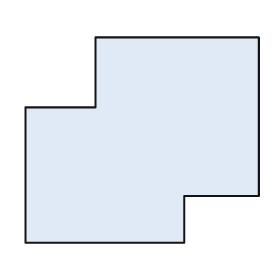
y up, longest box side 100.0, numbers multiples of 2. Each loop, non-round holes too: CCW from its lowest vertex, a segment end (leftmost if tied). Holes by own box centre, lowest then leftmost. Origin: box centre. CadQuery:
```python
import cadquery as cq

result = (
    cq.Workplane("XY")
    .moveTo(-50.0, -44.0)
    .lineTo(18.0, -44.0)
    .lineTo(18.0, -24.0)
    .lineTo(50.0, -24.0)
    .lineTo(50.0, 44.0)
    .lineTo(-20.0, 44.0)
    .lineTo(-20.0, 14.0)
    .lineTo(-50.0, 14.0)
    .close()
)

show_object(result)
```